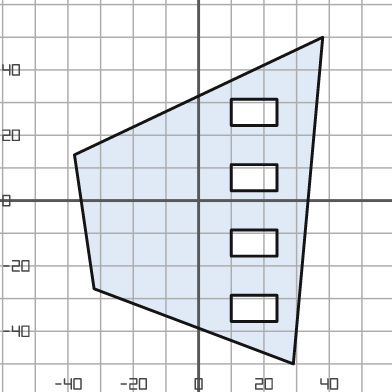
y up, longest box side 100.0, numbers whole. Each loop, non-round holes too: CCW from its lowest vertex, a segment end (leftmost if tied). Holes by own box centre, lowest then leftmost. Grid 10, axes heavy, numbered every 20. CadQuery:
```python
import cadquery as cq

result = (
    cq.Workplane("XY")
    .moveTo(29.0, -50.0)
    .lineTo(38.0, 50.0)
    .lineTo(-38.0, 14.0)
    .lineTo(-32.0, -27.0)
    .close()
    .moveTo(10.0, -37.0)
    .lineTo(24.0, -37.0)
    .lineTo(24.0, -29.0)
    .lineTo(10.0, -29.0)
    .close()
    .moveTo(10.0, -17.0)
    .lineTo(24.0, -17.0)
    .lineTo(24.0, -9.0)
    .lineTo(10.0, -9.0)
    .close()
    .moveTo(10.0, 3.0)
    .lineTo(24.0, 3.0)
    .lineTo(24.0, 11.0)
    .lineTo(10.0, 11.0)
    .close()
    .moveTo(10.0, 23.0)
    .lineTo(24.0, 23.0)
    .lineTo(24.0, 31.0)
    .lineTo(10.0, 31.0)
    .close()
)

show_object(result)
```